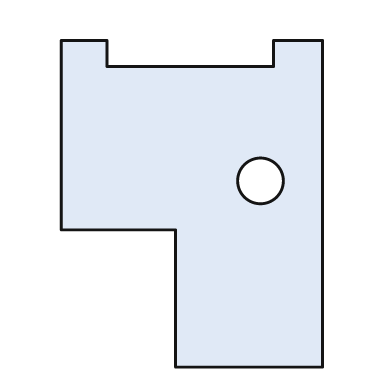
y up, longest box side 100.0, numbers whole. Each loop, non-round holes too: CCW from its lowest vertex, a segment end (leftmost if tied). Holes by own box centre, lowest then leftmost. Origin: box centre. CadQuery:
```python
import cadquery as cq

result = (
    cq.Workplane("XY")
    .moveTo(-5.0, -50.0)
    .lineTo(40.0, -50.0)
    .lineTo(40.0, 50.0)
    .lineTo(25.0, 50.0)
    .lineTo(25.0, 42.0)
    .lineTo(-26.0, 42.0)
    .lineTo(-26.0, 50.0)
    .lineTo(-40.0, 50.0)
    .lineTo(-40.0, -8.0)
    .lineTo(-5.0, -8.0)
    .close()
    .moveTo(21.0, 7.0)
    .circle(7.0)
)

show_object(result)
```